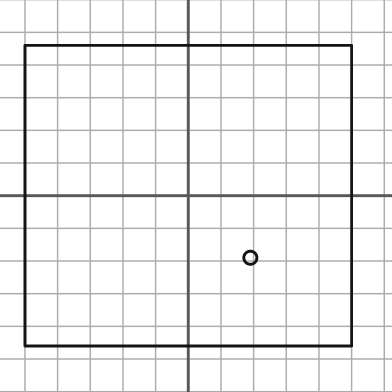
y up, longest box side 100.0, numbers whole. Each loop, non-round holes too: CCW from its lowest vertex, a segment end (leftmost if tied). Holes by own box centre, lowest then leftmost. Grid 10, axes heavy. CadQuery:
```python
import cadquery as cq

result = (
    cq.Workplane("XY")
    .moveTo(-50.0, -46.0)
    .lineTo(50.0, -46.0)
    .lineTo(50.0, 46.0)
    .lineTo(-50.0, 46.0)
    .close()
    .moveTo(19.0, -19.0)
    .circle(2.0)
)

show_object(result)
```